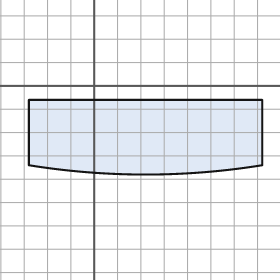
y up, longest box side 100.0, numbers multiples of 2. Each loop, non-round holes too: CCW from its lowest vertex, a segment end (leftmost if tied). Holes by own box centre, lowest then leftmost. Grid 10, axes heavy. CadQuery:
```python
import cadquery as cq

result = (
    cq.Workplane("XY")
    .moveTo(-28.0, -34.0)
    .threePointArc((22.0, -38.0), (72.0, -34.0))
    .lineTo(72.0, -6.0)
    .lineTo(-28.0, -6.0)
    .close()
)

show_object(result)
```